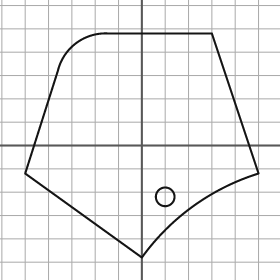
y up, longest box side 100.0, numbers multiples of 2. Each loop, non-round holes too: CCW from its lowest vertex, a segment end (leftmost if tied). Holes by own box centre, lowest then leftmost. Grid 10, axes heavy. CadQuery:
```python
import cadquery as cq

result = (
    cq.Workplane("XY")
    .moveTo(0.0, -48.0)
    .threePointArc((22.0, -26.0), (50.0, -12.0))
    .lineTo(30.0, 48.0)
    .lineTo(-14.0, 48.0)
    .threePointArc((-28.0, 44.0), (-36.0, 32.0))
    .lineTo(-50.0, -12.0)
    .close()
    .moveTo(10.0, -22.0)
    .circle(4.0)
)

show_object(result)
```